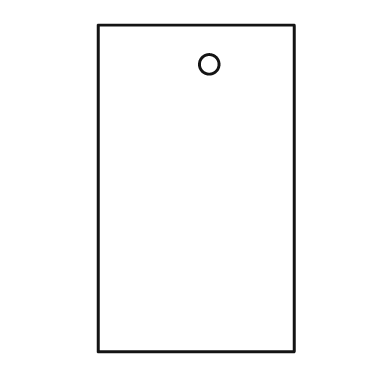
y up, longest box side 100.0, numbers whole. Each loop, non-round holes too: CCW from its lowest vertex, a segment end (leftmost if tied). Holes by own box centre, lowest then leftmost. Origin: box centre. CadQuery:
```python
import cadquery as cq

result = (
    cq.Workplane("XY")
    .moveTo(-30.0, -50.0)
    .lineTo(30.0, -50.0)
    .lineTo(30.0, 50.0)
    .lineTo(-30.0, 50.0)
    .close()
    .moveTo(4.0, 38.0)
    .circle(3.0)
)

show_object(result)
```